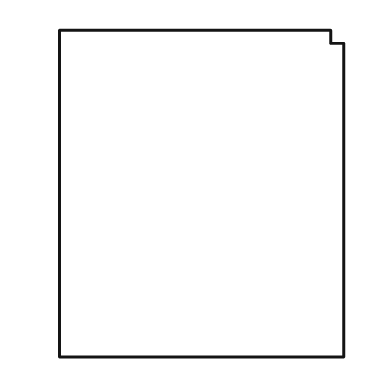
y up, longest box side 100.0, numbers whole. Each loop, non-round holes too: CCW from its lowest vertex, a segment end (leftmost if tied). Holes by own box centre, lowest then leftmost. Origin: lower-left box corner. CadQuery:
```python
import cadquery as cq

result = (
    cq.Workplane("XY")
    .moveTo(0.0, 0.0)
    .lineTo(87.0, 0.0)
    .lineTo(87.0, 96.0)
    .lineTo(83.0, 96.0)
    .lineTo(83.0, 100.0)
    .lineTo(0.0, 100.0)
    .close()
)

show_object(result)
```